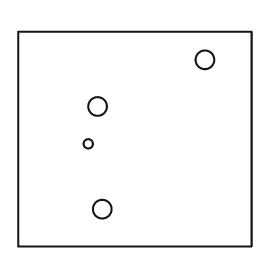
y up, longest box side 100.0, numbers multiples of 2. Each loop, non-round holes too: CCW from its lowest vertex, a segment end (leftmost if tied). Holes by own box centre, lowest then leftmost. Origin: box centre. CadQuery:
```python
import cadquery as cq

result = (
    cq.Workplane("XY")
    .moveTo(-50.0, -46.0)
    .lineTo(50.0, -46.0)
    .lineTo(50.0, 46.0)
    .lineTo(-50.0, 46.0)
    .close()
    .moveTo(-14.0, -30.0)
    .circle(4.0)
    .moveTo(-20.0, -2.0)
    .circle(2.0)
    .moveTo(-16.0, 14.0)
    .circle(4.0)
    .moveTo(30.0, 34.0)
    .circle(4.0)
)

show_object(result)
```